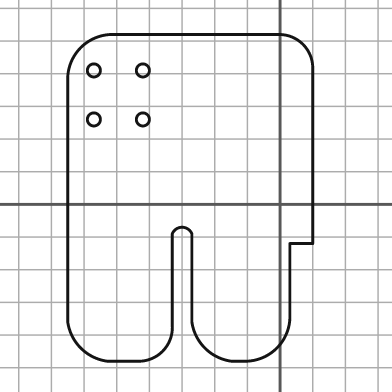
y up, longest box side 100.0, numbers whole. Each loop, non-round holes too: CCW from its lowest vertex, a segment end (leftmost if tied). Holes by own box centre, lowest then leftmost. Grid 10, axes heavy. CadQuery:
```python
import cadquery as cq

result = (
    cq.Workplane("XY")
    .moveTo(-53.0, -48.0)
    .lineTo(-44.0, -48.0)
    .threePointArc((-36.0, -45.0), (-33.0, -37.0))
    .lineTo(-33.0, -9.0)
    .threePointArc((-30.0, -7.0), (-27.0, -9.0))
    .lineTo(-27.0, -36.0)
    .threePointArc((-23.0, -44.0), (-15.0, -48.0))
    .lineTo(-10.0, -48.0)
    .threePointArc((-1.0, -44.0), (3.0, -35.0))
    .lineTo(3.0, -12.0)
    .lineTo(10.0, -12.0)
    .lineTo(10.0, 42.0)
    .threePointArc((7.0, 49.0), (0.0, 52.0))
    .lineTo(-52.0, 52.0)
    .threePointArc((-61.0, 48.0), (-65.0, 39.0))
    .lineTo(-65.0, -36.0)
    .threePointArc((-61.0, -44.0), (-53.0, -48.0))
    .close()
    .moveTo(-57.0, 26.0)
    .circle(2.0)
    .moveTo(-42.0, 26.0)
    .circle(2.0)
    .moveTo(-57.0, 41.0)
    .circle(2.0)
    .moveTo(-42.0, 41.0)
    .circle(2.0)
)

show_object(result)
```